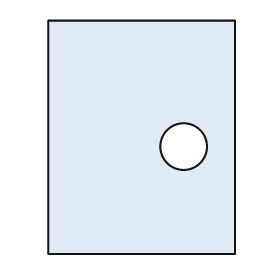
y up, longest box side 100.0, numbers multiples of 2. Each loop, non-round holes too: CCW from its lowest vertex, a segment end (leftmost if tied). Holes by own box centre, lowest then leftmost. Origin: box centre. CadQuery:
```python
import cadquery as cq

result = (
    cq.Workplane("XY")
    .moveTo(-40.0, -50.0)
    .lineTo(40.0, -50.0)
    .lineTo(40.0, 50.0)
    .lineTo(-40.0, 50.0)
    .close()
    .moveTo(18.0, -4.0)
    .circle(10.0)
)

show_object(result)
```